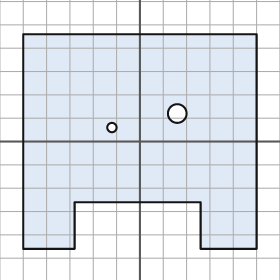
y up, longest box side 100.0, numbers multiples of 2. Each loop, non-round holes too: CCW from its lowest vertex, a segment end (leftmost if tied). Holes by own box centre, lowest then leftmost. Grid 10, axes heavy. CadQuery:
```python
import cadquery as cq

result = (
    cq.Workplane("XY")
    .moveTo(-50.0, -46.0)
    .lineTo(-28.0, -46.0)
    .lineTo(-28.0, -26.0)
    .lineTo(26.0, -26.0)
    .lineTo(26.0, -46.0)
    .lineTo(50.0, -46.0)
    .lineTo(50.0, 46.0)
    .lineTo(-50.0, 46.0)
    .close()
    .moveTo(-12.0, 6.0)
    .circle(2.0)
    .moveTo(16.0, 12.0)
    .circle(4.0)
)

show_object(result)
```